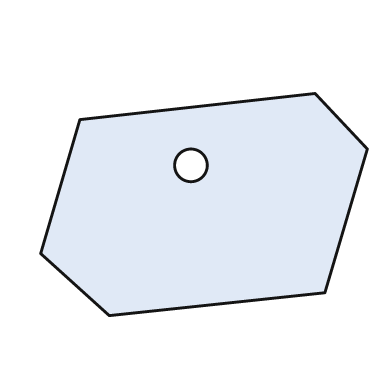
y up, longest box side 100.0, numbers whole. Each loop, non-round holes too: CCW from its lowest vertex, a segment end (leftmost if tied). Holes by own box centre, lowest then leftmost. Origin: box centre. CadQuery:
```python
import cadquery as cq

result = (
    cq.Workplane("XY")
    .moveTo(-29.0, -34.0)
    .lineTo(37.0, -27.0)
    .lineTo(50.0, 17.0)
    .lineTo(34.0, 34.0)
    .lineTo(-38.0, 26.0)
    .lineTo(-50.0, -15.0)
    .close()
    .moveTo(-4.0, 12.0)
    .circle(5.0)
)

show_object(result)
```